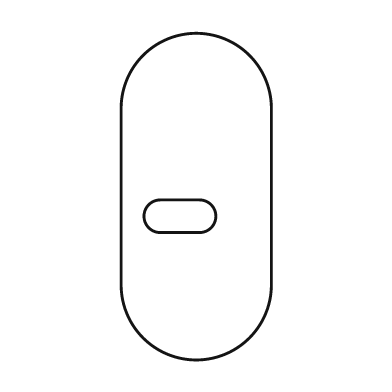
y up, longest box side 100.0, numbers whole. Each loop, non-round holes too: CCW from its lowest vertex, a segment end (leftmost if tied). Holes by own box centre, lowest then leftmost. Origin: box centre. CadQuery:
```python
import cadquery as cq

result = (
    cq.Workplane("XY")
    .moveTo(-23.0, -27.0)
    .threePointArc((0.0, -50.0), (23.0, -27.0))
    .lineTo(23.0, 27.0)
    .threePointArc((0.0, 50.0), (-23.0, 27.0))
    .close()
    .moveTo(-11.0, -11.0)
    .lineTo(1.0, -11.0)
    .threePointArc((6.0, -6.0), (1.0, -1.0))
    .lineTo(-11.0, -1.0)
    .threePointArc((-16.0, -6.0), (-11.0, -11.0))
    .close()
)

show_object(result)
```